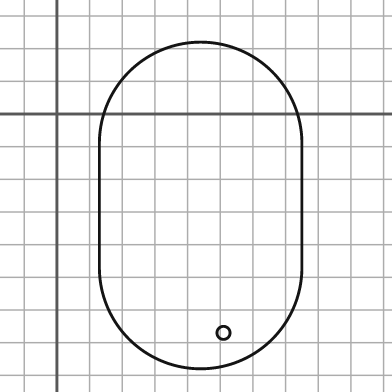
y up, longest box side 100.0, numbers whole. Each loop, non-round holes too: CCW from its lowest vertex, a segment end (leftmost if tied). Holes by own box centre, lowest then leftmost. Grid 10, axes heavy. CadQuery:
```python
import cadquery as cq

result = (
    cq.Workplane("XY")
    .moveTo(13.0, -47.0)
    .threePointArc((44.0, -78.0), (75.0, -47.0))
    .lineTo(75.0, -9.0)
    .threePointArc((44.0, 22.0), (13.0, -9.0))
    .close()
    .moveTo(51.0, -67.0)
    .circle(2.0)
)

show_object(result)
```